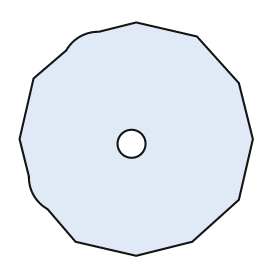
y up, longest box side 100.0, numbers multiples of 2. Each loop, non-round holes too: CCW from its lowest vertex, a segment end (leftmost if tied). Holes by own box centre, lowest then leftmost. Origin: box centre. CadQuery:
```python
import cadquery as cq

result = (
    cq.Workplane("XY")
    .moveTo(0.0, -50.0)
    .lineTo(24.0, -44.0)
    .lineTo(44.0, -26.0)
    .lineTo(50.0, 0.0)
    .lineTo(44.0, 24.0)
    .lineTo(26.0, 44.0)
    .lineTo(0.0, 50.0)
    .lineTo(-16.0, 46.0)
    .threePointArc((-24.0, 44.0), (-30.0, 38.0))
    .lineTo(-44.0, 26.0)
    .lineTo(-50.0, 0.0)
    .lineTo(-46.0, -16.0)
    .threePointArc((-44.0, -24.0), (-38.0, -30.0))
    .lineTo(-26.0, -44.0)
    .close()
    .moveTo(-2.0, -2.0)
    .circle(6.0)
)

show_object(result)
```